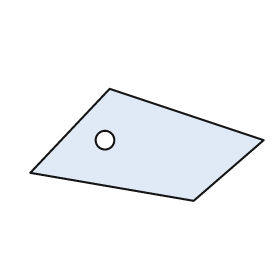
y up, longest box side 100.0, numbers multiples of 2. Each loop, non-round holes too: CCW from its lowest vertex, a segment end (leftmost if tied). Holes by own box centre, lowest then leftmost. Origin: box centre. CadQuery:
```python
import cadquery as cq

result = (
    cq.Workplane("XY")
    .moveTo(20.0, -24.0)
    .lineTo(50.0, 2.0)
    .lineTo(-16.0, 24.0)
    .lineTo(-50.0, -12.0)
    .close()
    .moveTo(-18.0, 2.0)
    .circle(4.0)
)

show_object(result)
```